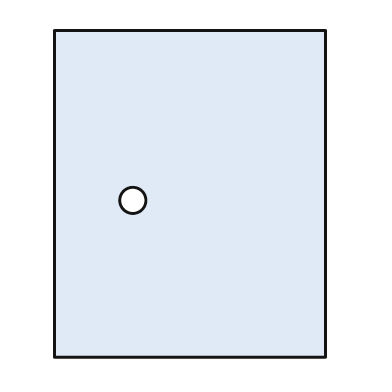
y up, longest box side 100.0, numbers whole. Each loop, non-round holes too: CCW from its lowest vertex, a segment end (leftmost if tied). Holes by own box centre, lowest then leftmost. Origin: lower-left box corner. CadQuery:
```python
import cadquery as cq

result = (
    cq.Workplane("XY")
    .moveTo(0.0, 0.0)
    .lineTo(83.0, 0.0)
    .lineTo(83.0, 100.0)
    .lineTo(0.0, 100.0)
    .close()
    .moveTo(24.0, 48.0)
    .circle(4.0)
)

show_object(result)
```